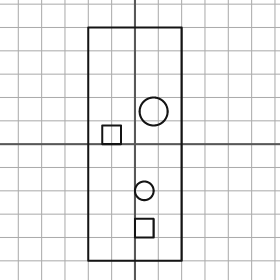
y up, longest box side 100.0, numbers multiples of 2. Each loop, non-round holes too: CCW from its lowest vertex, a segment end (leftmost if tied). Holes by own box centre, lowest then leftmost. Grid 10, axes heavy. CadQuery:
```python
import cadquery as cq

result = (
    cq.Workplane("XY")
    .moveTo(-20.0, -50.0)
    .lineTo(20.0, -50.0)
    .lineTo(20.0, 50.0)
    .lineTo(-20.0, 50.0)
    .close()
    .moveTo(0.0, -40.0)
    .lineTo(8.0, -40.0)
    .lineTo(8.0, -32.0)
    .lineTo(0.0, -32.0)
    .close()
    .moveTo(4.0, -20.0)
    .circle(4.0)
    .moveTo(-14.0, 0.0)
    .lineTo(-6.0, 0.0)
    .lineTo(-6.0, 8.0)
    .lineTo(-14.0, 8.0)
    .close()
    .moveTo(8.0, 14.0)
    .circle(6.0)
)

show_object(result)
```